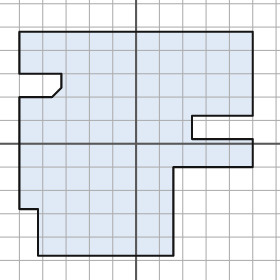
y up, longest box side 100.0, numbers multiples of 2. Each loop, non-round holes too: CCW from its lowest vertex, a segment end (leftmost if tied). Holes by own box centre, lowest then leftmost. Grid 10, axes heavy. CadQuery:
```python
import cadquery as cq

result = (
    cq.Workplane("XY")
    .moveTo(-42.0, -48.0)
    .lineTo(16.0, -48.0)
    .lineTo(16.0, -10.0)
    .lineTo(50.0, -10.0)
    .lineTo(50.0, 2.0)
    .lineTo(24.0, 2.0)
    .lineTo(24.0, 12.0)
    .lineTo(50.0, 12.0)
    .lineTo(50.0, 48.0)
    .lineTo(-50.0, 48.0)
    .lineTo(-50.0, 30.0)
    .lineTo(-32.0, 30.0)
    .lineTo(-32.0, 24.0)
    .lineTo(-36.0, 20.0)
    .lineTo(-50.0, 20.0)
    .lineTo(-50.0, -28.0)
    .lineTo(-42.0, -28.0)
    .close()
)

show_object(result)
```